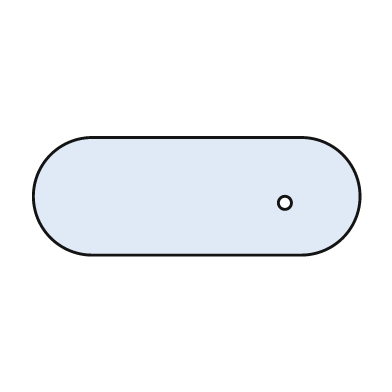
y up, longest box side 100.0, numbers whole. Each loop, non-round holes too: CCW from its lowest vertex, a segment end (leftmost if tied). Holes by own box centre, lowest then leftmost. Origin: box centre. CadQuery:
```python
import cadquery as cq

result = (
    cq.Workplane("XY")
    .moveTo(-32.0, -18.0)
    .lineTo(32.0, -18.0)
    .threePointArc((50.0, 0.0), (32.0, 18.0))
    .lineTo(-32.0, 18.0)
    .threePointArc((-50.0, 0.0), (-32.0, -18.0))
    .close()
    .moveTo(27.0, -2.0)
    .circle(2.0)
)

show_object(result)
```